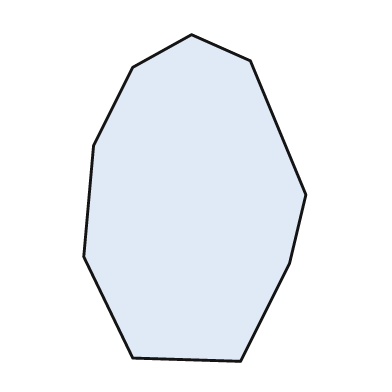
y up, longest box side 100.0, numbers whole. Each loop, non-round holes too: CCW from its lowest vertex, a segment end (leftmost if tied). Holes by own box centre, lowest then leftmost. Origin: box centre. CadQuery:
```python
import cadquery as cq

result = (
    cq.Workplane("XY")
    .moveTo(14.0, -50.0)
    .lineTo(29.0, -20.0)
    .lineTo(34.0, 1.0)
    .lineTo(17.0, 42.0)
    .lineTo(-1.0, 50.0)
    .lineTo(-19.0, 40.0)
    .lineTo(-31.0, 16.0)
    .lineTo(-34.0, -18.0)
    .lineTo(-19.0, -49.0)
    .close()
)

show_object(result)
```